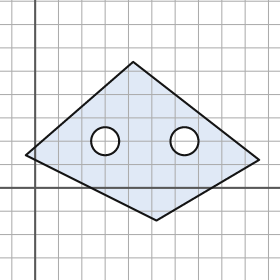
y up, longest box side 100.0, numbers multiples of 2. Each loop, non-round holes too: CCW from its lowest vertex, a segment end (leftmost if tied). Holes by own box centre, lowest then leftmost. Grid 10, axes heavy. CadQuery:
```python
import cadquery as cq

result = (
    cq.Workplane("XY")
    .moveTo(52.0, -14.0)
    .lineTo(96.0, 12.0)
    .lineTo(42.0, 54.0)
    .lineTo(-4.0, 14.0)
    .close()
    .moveTo(30.0, 20.0)
    .circle(6.0)
    .moveTo(64.0, 20.0)
    .circle(6.0)
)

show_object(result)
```